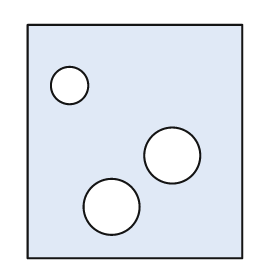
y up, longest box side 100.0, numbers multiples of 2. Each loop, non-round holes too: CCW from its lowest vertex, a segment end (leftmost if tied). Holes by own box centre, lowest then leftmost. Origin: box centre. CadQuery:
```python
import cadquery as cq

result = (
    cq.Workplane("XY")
    .moveTo(-46.0, -50.0)
    .lineTo(46.0, -50.0)
    .lineTo(46.0, 50.0)
    .lineTo(-46.0, 50.0)
    .close()
    .moveTo(-10.0, -28.0)
    .circle(12.0)
    .moveTo(16.0, -6.0)
    .circle(12.0)
    .moveTo(-28.0, 24.0)
    .circle(8.0)
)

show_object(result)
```